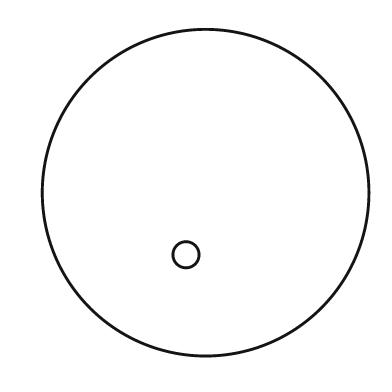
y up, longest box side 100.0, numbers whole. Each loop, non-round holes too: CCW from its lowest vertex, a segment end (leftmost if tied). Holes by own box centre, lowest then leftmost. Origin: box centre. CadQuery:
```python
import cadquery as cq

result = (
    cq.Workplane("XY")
    .moveTo(0.0, 0.0)
    .circle(50.0)
    .moveTo(-6.0, -19.0)
    .circle(4.0)
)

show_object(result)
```